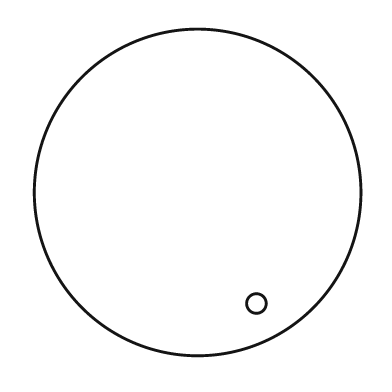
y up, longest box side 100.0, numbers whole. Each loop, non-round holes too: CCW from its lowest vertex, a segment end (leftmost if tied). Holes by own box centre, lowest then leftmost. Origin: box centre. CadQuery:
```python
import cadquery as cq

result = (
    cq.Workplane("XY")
    .moveTo(0.0, 0.0)
    .circle(50.0)
    .moveTo(18.0, -34.0)
    .circle(3.0)
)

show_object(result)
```